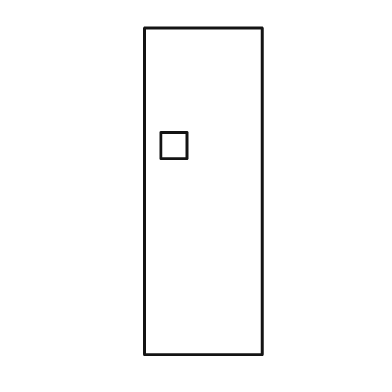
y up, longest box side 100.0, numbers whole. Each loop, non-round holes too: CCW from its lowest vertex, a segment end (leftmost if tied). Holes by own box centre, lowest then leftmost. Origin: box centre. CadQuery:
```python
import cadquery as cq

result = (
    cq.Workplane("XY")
    .moveTo(-18.0, -50.0)
    .lineTo(18.0, -50.0)
    .lineTo(18.0, 50.0)
    .lineTo(-18.0, 50.0)
    .close()
    .moveTo(-13.0, 10.0)
    .lineTo(-5.0, 10.0)
    .lineTo(-5.0, 18.0)
    .lineTo(-13.0, 18.0)
    .close()
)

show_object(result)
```